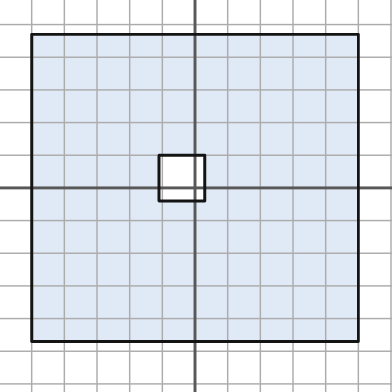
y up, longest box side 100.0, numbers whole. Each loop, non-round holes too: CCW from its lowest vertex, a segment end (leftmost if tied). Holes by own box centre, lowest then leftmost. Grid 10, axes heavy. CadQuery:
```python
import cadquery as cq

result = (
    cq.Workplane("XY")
    .moveTo(-50.0, -47.0)
    .lineTo(50.0, -47.0)
    .lineTo(50.0, 47.0)
    .lineTo(-50.0, 47.0)
    .close()
    .moveTo(-11.0, -4.0)
    .lineTo(3.0, -4.0)
    .lineTo(3.0, 10.0)
    .lineTo(-11.0, 10.0)
    .close()
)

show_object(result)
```